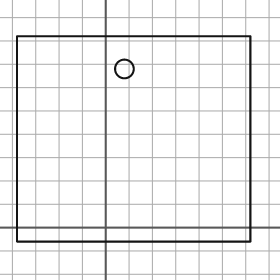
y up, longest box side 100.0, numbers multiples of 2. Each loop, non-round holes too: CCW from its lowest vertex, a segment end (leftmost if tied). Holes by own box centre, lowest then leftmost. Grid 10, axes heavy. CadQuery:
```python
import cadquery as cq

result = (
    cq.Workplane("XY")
    .moveTo(-38.0, -6.0)
    .lineTo(62.0, -6.0)
    .lineTo(62.0, 82.0)
    .lineTo(-38.0, 82.0)
    .close()
    .moveTo(8.0, 68.0)
    .circle(4.0)
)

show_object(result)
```